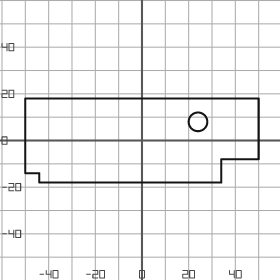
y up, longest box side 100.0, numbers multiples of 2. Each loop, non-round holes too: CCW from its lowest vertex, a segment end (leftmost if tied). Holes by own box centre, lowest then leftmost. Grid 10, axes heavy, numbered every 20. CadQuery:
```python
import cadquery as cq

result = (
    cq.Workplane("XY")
    .moveTo(-44.0, -18.0)
    .lineTo(34.0, -18.0)
    .lineTo(34.0, -8.0)
    .lineTo(50.0, -8.0)
    .lineTo(50.0, 18.0)
    .lineTo(-50.0, 18.0)
    .lineTo(-50.0, -14.0)
    .lineTo(-44.0, -14.0)
    .close()
    .moveTo(24.0, 8.0)
    .circle(4.0)
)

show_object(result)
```